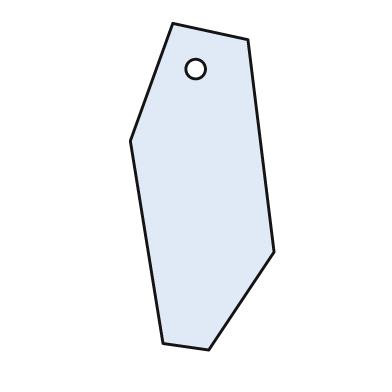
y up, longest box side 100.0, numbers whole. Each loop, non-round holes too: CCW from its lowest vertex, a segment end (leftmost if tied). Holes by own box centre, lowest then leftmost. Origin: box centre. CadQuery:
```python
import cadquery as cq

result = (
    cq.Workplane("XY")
    .moveTo(2.0, -50.0)
    .lineTo(22.0, -20.0)
    .lineTo(14.0, 45.0)
    .lineTo(-9.0, 50.0)
    .lineTo(-22.0, 14.0)
    .lineTo(-12.0, -48.0)
    .close()
    .moveTo(-2.0, 36.0)
    .circle(3.0)
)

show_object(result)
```